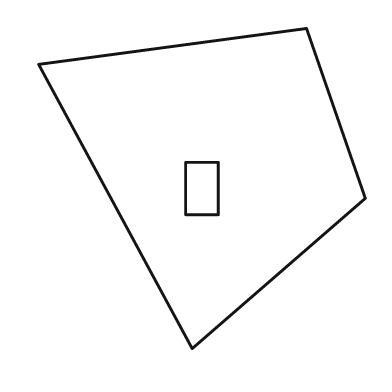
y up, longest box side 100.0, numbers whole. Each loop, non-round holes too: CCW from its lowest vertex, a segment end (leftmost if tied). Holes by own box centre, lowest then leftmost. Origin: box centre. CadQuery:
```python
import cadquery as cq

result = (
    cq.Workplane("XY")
    .moveTo(-3.0, -49.0)
    .lineTo(50.0, -3.0)
    .lineTo(32.0, 49.0)
    .lineTo(-50.0, 38.0)
    .close()
    .moveTo(-5.0, -8.0)
    .lineTo(5.0, -8.0)
    .lineTo(5.0, 8.0)
    .lineTo(-5.0, 8.0)
    .close()
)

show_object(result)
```